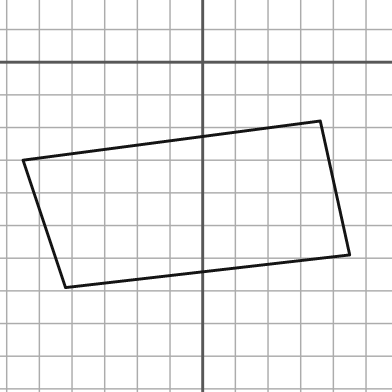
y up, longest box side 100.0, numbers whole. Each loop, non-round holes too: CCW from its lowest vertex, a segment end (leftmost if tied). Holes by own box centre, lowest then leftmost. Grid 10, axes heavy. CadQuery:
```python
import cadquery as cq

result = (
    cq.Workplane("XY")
    .moveTo(-42.0, -69.0)
    .lineTo(45.0, -59.0)
    .lineTo(36.0, -18.0)
    .lineTo(-55.0, -30.0)
    .close()
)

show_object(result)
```